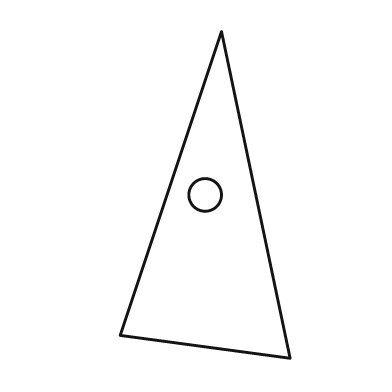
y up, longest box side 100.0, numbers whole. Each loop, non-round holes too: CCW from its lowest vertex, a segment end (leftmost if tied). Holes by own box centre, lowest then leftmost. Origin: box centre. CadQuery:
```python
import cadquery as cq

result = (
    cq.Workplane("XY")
    .moveTo(26.0, -50.0)
    .lineTo(5.0, 50.0)
    .lineTo(-26.0, -43.0)
    .close()
    .moveTo(0.0, 0.0)
    .circle(5.0)
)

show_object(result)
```